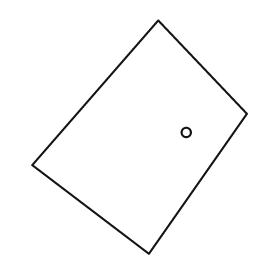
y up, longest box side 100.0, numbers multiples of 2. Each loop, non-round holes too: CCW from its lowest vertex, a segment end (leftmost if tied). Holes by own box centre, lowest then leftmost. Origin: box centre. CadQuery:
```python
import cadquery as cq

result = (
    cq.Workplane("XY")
    .moveTo(4.0, -50.0)
    .lineTo(46.0, 10.0)
    .lineTo(8.0, 50.0)
    .lineTo(-46.0, -12.0)
    .close()
    .moveTo(20.0, 2.0)
    .circle(2.0)
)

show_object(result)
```